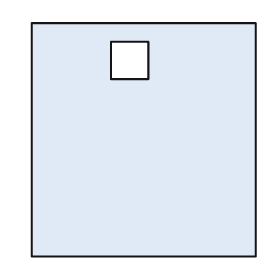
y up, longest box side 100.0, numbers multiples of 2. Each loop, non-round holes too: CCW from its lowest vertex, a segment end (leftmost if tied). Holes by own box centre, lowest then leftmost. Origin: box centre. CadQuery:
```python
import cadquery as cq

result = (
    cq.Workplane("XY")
    .moveTo(-48.0, -50.0)
    .lineTo(48.0, -50.0)
    .lineTo(48.0, 50.0)
    .lineTo(-48.0, 50.0)
    .close()
    .moveTo(-14.0, 26.0)
    .lineTo(2.0, 26.0)
    .lineTo(2.0, 42.0)
    .lineTo(-14.0, 42.0)
    .close()
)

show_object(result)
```